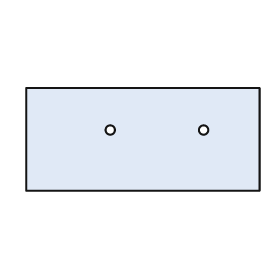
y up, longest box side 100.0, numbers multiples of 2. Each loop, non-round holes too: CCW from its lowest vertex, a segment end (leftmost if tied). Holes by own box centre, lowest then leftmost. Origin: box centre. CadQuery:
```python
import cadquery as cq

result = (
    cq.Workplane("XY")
    .moveTo(-50.0, -22.0)
    .lineTo(50.0, -22.0)
    .lineTo(50.0, 22.0)
    .lineTo(-50.0, 22.0)
    .close()
    .moveTo(-14.0, 4.0)
    .circle(2.0)
    .moveTo(26.0, 4.0)
    .circle(2.0)
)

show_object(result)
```